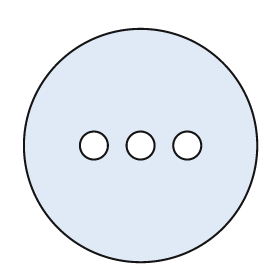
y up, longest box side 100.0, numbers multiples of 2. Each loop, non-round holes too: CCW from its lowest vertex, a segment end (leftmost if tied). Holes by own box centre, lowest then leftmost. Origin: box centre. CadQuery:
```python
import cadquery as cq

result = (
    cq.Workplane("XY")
    .moveTo(0.0, 0.0)
    .circle(50.0)
    .moveTo(-20.0, 0.0)
    .circle(6.0)
    .moveTo(0.0, 0.0)
    .circle(6.0)
    .moveTo(20.0, 0.0)
    .circle(6.0)
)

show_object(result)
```